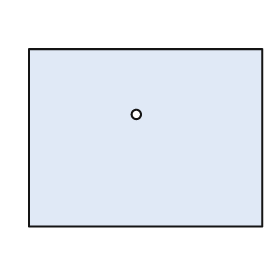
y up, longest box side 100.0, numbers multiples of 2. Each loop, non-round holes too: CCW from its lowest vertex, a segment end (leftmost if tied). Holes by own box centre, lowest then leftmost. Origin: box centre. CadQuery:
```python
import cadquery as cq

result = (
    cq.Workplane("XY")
    .moveTo(-50.0, -38.0)
    .lineTo(50.0, -38.0)
    .lineTo(50.0, 38.0)
    .lineTo(-50.0, 38.0)
    .close()
    .moveTo(-4.0, 10.0)
    .circle(2.0)
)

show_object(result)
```